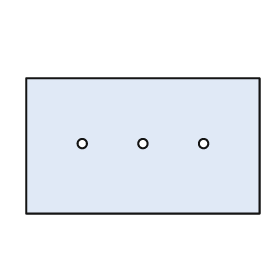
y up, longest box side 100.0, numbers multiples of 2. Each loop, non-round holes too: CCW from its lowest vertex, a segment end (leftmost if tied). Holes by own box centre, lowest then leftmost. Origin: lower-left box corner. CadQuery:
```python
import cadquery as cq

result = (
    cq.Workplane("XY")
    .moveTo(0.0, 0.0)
    .lineTo(100.0, 0.0)
    .lineTo(100.0, 58.0)
    .lineTo(0.0, 58.0)
    .close()
    .moveTo(24.0, 30.0)
    .circle(2.0)
    .moveTo(50.0, 30.0)
    .circle(2.0)
    .moveTo(76.0, 30.0)
    .circle(2.0)
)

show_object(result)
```